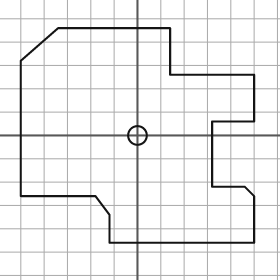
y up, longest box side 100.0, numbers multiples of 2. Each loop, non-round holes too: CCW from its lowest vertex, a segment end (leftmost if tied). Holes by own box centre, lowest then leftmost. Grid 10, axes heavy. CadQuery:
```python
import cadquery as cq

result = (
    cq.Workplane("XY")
    .moveTo(-12.0, -46.0)
    .lineTo(50.0, -46.0)
    .lineTo(50.0, -26.0)
    .lineTo(46.0, -22.0)
    .lineTo(32.0, -22.0)
    .lineTo(32.0, 6.0)
    .lineTo(50.0, 6.0)
    .lineTo(50.0, 26.0)
    .lineTo(14.0, 26.0)
    .lineTo(14.0, 46.0)
    .lineTo(-34.0, 46.0)
    .lineTo(-50.0, 32.0)
    .lineTo(-50.0, -26.0)
    .lineTo(-18.0, -26.0)
    .lineTo(-12.0, -34.0)
    .close()
    .moveTo(0.0, 0.0)
    .circle(4.0)
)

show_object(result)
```